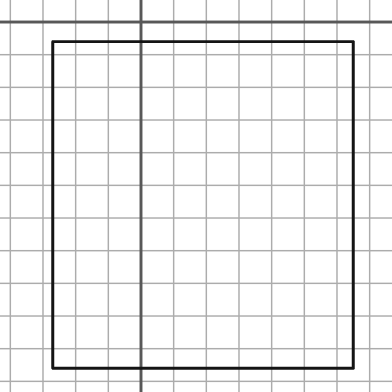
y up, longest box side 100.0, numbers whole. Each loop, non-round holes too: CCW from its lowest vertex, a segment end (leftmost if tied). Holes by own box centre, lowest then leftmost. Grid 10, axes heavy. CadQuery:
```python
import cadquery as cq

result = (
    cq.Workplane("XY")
    .moveTo(-27.0, -106.0)
    .lineTo(65.0, -106.0)
    .lineTo(65.0, -6.0)
    .lineTo(-27.0, -6.0)
    .close()
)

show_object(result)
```